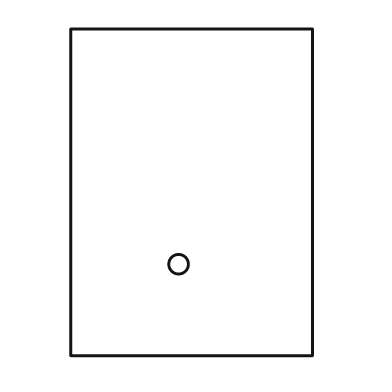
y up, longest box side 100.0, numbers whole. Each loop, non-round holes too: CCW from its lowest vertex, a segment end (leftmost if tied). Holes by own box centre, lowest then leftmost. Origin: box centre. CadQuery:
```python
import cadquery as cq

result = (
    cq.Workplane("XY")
    .moveTo(-37.0, -50.0)
    .lineTo(37.0, -50.0)
    .lineTo(37.0, 50.0)
    .lineTo(-37.0, 50.0)
    .close()
    .moveTo(-4.0, -22.0)
    .circle(3.0)
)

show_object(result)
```